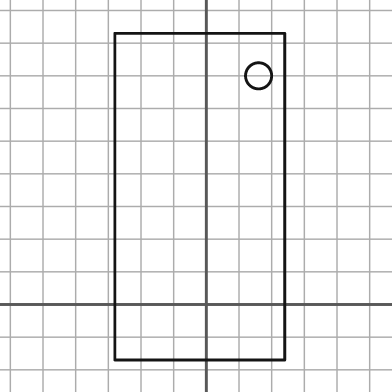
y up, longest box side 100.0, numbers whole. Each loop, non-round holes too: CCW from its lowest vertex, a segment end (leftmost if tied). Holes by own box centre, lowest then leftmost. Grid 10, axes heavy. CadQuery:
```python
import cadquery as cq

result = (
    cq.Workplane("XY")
    .moveTo(-28.0, -17.0)
    .lineTo(24.0, -17.0)
    .lineTo(24.0, 83.0)
    .lineTo(-28.0, 83.0)
    .close()
    .moveTo(16.0, 70.0)
    .circle(4.0)
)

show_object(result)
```